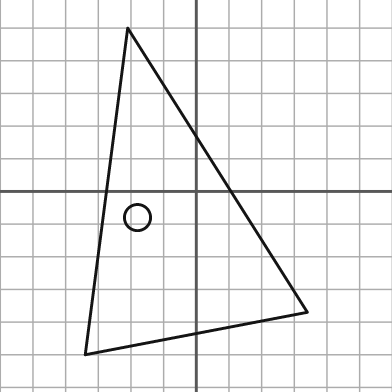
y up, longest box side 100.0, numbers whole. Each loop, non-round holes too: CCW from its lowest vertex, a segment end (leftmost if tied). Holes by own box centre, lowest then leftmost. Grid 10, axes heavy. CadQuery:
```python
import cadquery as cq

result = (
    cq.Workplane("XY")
    .moveTo(-34.0, -50.0)
    .lineTo(34.0, -37.0)
    .lineTo(-21.0, 50.0)
    .close()
    .moveTo(-18.0, -8.0)
    .circle(4.0)
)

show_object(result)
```